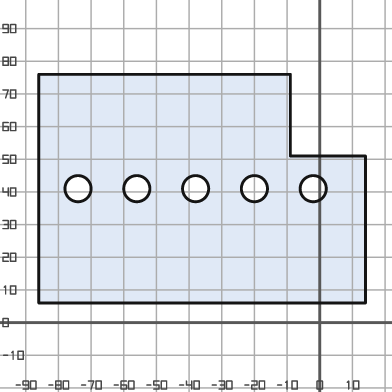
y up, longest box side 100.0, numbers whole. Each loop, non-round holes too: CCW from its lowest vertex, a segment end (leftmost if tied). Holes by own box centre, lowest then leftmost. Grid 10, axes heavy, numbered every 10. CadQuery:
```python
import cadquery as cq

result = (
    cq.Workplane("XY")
    .moveTo(-86.0, 6.0)
    .lineTo(14.0, 6.0)
    .lineTo(14.0, 51.0)
    .lineTo(-9.0, 51.0)
    .lineTo(-9.0, 76.0)
    .lineTo(-86.0, 76.0)
    .close()
    .moveTo(-74.0, 41.0)
    .circle(4.0)
    .moveTo(-56.0, 41.0)
    .circle(4.0)
    .moveTo(-38.0, 41.0)
    .circle(4.0)
    .moveTo(-20.0, 41.0)
    .circle(4.0)
    .moveTo(-2.0, 41.0)
    .circle(4.0)
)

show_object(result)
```